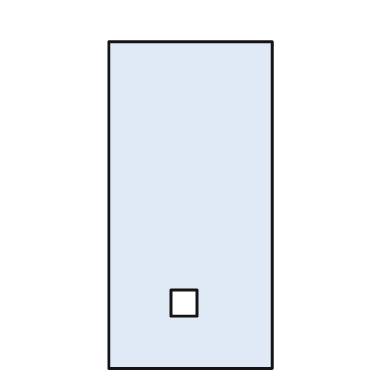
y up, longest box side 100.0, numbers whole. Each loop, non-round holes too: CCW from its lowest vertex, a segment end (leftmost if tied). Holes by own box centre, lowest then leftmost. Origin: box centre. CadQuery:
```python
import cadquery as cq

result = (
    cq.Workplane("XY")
    .moveTo(-25.0, -50.0)
    .lineTo(25.0, -50.0)
    .lineTo(25.0, 50.0)
    .lineTo(-25.0, 50.0)
    .close()
    .moveTo(-6.0, -34.0)
    .lineTo(2.0, -34.0)
    .lineTo(2.0, -26.0)
    .lineTo(-6.0, -26.0)
    .close()
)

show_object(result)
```